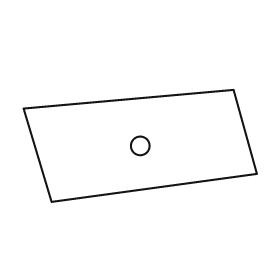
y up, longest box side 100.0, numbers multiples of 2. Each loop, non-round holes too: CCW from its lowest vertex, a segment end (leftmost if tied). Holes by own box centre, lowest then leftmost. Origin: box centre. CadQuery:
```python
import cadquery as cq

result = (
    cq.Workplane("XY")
    .moveTo(-38.0, -24.0)
    .lineTo(50.0, -12.0)
    .lineTo(40.0, 24.0)
    .lineTo(-50.0, 16.0)
    .close()
    .moveTo(0.0, 0.0)
    .circle(4.0)
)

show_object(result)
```